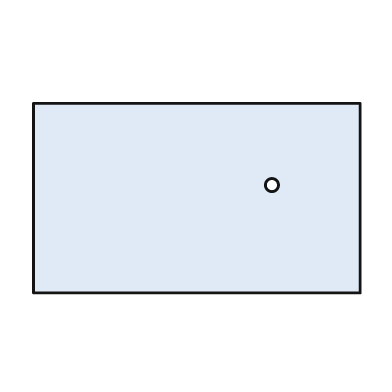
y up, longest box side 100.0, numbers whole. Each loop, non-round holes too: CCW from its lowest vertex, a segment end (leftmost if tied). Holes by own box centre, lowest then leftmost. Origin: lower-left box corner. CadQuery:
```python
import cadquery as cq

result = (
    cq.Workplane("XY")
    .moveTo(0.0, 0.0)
    .lineTo(100.0, 0.0)
    .lineTo(100.0, 58.0)
    .lineTo(0.0, 58.0)
    .close()
    .moveTo(73.0, 33.0)
    .circle(2.0)
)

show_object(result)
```